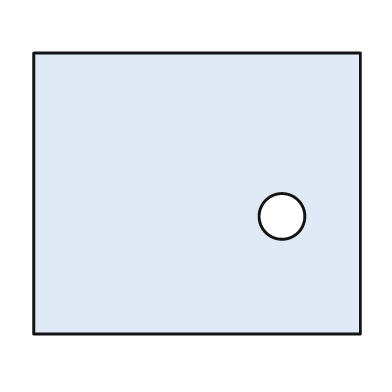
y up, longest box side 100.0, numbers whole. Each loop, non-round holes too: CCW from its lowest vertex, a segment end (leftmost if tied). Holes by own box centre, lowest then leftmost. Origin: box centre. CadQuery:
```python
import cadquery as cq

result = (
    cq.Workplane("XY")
    .moveTo(-50.0, -43.0)
    .lineTo(50.0, -43.0)
    .lineTo(50.0, 43.0)
    .lineTo(-50.0, 43.0)
    .close()
    .moveTo(26.0, -7.0)
    .circle(7.0)
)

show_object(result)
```